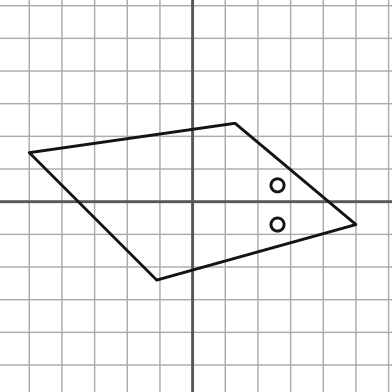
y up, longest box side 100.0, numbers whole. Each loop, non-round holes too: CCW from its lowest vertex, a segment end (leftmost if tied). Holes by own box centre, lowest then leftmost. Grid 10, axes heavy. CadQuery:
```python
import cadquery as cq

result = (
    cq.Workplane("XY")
    .moveTo(-11.0, -24.0)
    .lineTo(50.0, -7.0)
    .lineTo(13.0, 24.0)
    .lineTo(-50.0, 15.0)
    .close()
    .moveTo(26.0, -7.0)
    .circle(2.0)
    .moveTo(26.0, 5.0)
    .circle(2.0)
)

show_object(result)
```